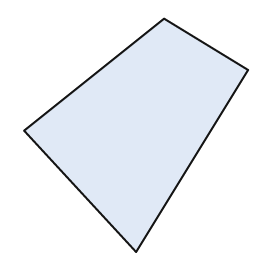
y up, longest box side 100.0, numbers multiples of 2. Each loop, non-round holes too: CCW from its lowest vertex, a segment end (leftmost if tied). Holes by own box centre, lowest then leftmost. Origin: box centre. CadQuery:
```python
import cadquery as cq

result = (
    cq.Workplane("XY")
    .moveTo(0.0, -50.0)
    .lineTo(48.0, 28.0)
    .lineTo(12.0, 50.0)
    .lineTo(-48.0, 2.0)
    .close()
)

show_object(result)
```